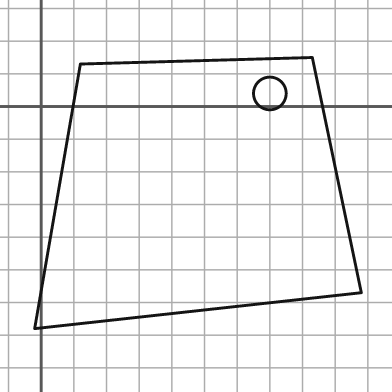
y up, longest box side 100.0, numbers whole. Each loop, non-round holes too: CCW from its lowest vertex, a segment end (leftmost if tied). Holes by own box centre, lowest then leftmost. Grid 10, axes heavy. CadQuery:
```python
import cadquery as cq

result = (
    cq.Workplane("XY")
    .moveTo(-2.0, -68.0)
    .lineTo(98.0, -57.0)
    .lineTo(83.0, 15.0)
    .lineTo(12.0, 13.0)
    .close()
    .moveTo(70.0, 4.0)
    .circle(5.0)
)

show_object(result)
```